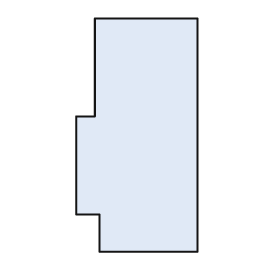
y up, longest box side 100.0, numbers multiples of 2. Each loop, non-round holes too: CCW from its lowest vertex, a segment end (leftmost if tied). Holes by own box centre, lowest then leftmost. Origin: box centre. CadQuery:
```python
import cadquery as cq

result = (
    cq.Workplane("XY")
    .moveTo(-16.0, -50.0)
    .lineTo(26.0, -50.0)
    .lineTo(26.0, 50.0)
    .lineTo(-18.0, 50.0)
    .lineTo(-18.0, 8.0)
    .lineTo(-26.0, 8.0)
    .lineTo(-26.0, -34.0)
    .lineTo(-16.0, -34.0)
    .close()
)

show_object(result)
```